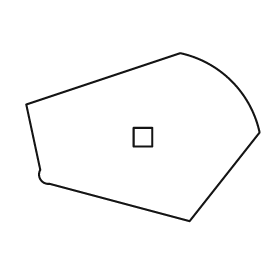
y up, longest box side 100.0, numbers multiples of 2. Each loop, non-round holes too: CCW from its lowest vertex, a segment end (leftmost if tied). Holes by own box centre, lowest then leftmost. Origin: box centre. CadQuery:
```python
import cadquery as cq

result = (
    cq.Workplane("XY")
    .moveTo(20.0, -36.0)
    .lineTo(50.0, 2.0)
    .threePointArc((38.0, 24.0), (16.0, 36.0))
    .lineTo(-50.0, 14.0)
    .lineTo(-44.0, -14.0)
    .threePointArc((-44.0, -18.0), (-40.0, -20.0))
    .close()
    .moveTo(-4.0, -4.0)
    .lineTo(4.0, -4.0)
    .lineTo(4.0, 4.0)
    .lineTo(-4.0, 4.0)
    .close()
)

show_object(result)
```